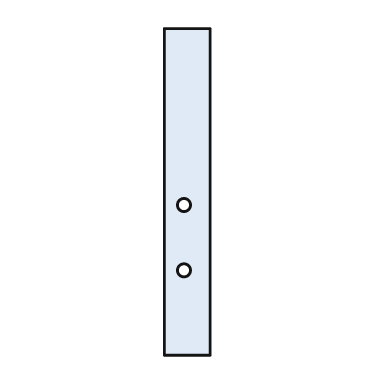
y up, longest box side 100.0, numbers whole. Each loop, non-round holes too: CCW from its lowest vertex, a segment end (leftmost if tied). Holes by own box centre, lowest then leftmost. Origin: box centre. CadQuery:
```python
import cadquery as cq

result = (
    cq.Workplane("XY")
    .moveTo(-7.0, -50.0)
    .lineTo(7.0, -50.0)
    .lineTo(7.0, 50.0)
    .lineTo(-7.0, 50.0)
    .close()
    .moveTo(-1.0, -24.0)
    .circle(2.0)
    .moveTo(-1.0, -4.0)
    .circle(2.0)
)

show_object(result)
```